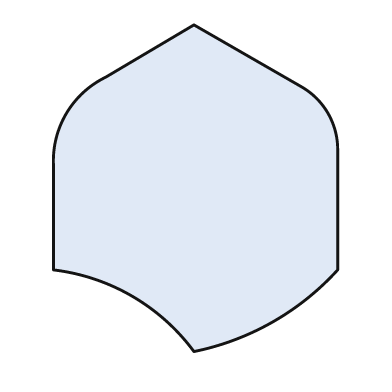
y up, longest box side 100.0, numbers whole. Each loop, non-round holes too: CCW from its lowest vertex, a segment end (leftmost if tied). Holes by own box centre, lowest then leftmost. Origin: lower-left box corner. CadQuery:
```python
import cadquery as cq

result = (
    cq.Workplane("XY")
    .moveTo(43.0, 0.0)
    .threePointArc((67.0, 9.0), (87.0, 25.0))
    .lineTo(87.0, 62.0)
    .threePointArc((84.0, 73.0), (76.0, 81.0))
    .lineTo(43.0, 100.0)
    .lineTo(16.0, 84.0)
    .threePointArc((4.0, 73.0), (0.0, 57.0))
    .lineTo(0.0, 25.0)
    .threePointArc((24.0, 17.0), (43.0, 0.0))
    .close()
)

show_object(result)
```